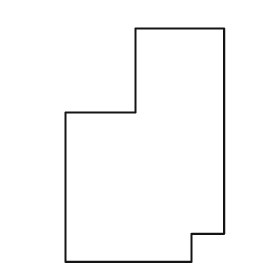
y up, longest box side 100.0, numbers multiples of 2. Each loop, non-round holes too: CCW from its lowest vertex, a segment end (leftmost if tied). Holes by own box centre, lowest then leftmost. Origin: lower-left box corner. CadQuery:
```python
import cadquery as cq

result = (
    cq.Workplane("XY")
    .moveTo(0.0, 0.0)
    .lineTo(54.0, 0.0)
    .lineTo(54.0, 12.0)
    .lineTo(68.0, 12.0)
    .lineTo(68.0, 100.0)
    .lineTo(30.0, 100.0)
    .lineTo(30.0, 64.0)
    .lineTo(0.0, 64.0)
    .close()
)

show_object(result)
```